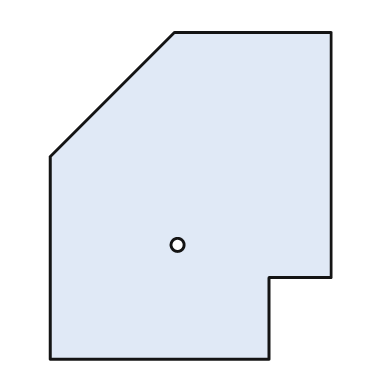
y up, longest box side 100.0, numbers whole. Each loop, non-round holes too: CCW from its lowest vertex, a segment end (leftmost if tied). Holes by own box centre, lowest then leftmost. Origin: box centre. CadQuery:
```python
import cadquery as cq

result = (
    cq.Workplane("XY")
    .moveTo(-43.0, -50.0)
    .lineTo(24.0, -50.0)
    .lineTo(24.0, -25.0)
    .lineTo(43.0, -25.0)
    .lineTo(43.0, 50.0)
    .lineTo(-5.0, 50.0)
    .lineTo(-43.0, 12.0)
    .close()
    .moveTo(-4.0, -15.0)
    .circle(2.0)
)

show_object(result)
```